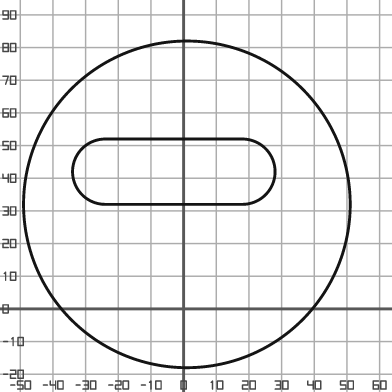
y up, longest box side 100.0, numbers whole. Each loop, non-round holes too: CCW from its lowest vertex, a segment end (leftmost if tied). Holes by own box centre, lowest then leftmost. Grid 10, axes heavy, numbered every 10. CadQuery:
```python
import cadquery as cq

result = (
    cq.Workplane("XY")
    .moveTo(1.0, 32.0)
    .circle(50.0)
    .moveTo(-24.0, 32.0)
    .lineTo(18.0, 32.0)
    .threePointArc((28.0, 42.0), (18.0, 52.0))
    .lineTo(-24.0, 52.0)
    .threePointArc((-34.0, 42.0), (-24.0, 32.0))
    .close()
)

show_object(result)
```